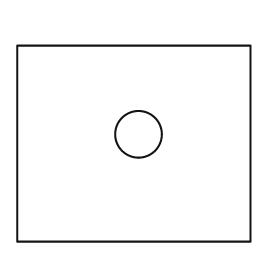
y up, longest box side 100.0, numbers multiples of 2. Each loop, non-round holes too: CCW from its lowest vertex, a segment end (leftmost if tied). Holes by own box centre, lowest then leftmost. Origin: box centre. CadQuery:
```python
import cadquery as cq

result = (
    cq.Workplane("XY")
    .moveTo(-50.0, -42.0)
    .lineTo(50.0, -42.0)
    .lineTo(50.0, 42.0)
    .lineTo(-50.0, 42.0)
    .close()
    .moveTo(2.0, 4.0)
    .circle(10.0)
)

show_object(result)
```